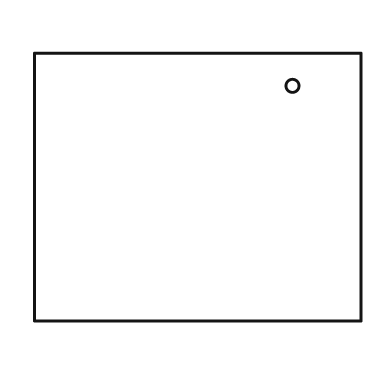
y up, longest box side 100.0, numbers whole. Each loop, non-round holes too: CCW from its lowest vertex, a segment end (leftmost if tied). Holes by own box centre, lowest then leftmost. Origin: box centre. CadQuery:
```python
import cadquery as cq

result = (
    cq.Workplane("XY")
    .moveTo(-50.0, -41.0)
    .lineTo(50.0, -41.0)
    .lineTo(50.0, 41.0)
    .lineTo(-50.0, 41.0)
    .close()
    .moveTo(29.0, 31.0)
    .circle(2.0)
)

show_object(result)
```